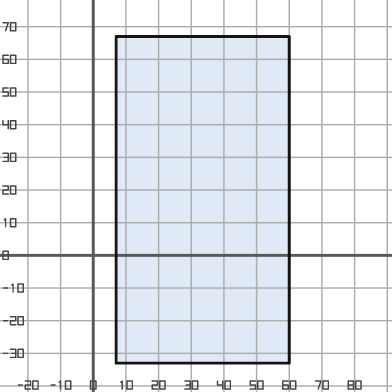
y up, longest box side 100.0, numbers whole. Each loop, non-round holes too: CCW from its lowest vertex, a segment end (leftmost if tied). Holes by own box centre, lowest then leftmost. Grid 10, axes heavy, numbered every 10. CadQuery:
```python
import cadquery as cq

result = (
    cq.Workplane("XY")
    .moveTo(7.0, -33.0)
    .lineTo(60.0, -33.0)
    .lineTo(60.0, 67.0)
    .lineTo(7.0, 67.0)
    .close()
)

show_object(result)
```